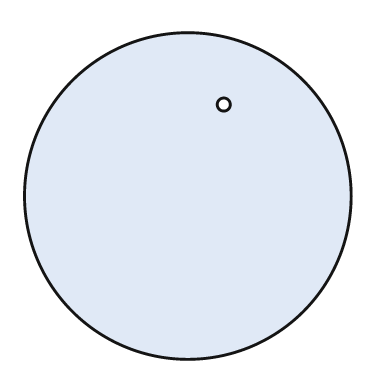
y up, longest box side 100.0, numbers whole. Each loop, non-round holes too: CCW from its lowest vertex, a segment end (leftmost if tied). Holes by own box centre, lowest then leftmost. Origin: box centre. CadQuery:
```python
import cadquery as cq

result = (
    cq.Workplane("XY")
    .moveTo(0.0, 0.0)
    .circle(50.0)
    .moveTo(11.0, 28.0)
    .circle(2.0)
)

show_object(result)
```